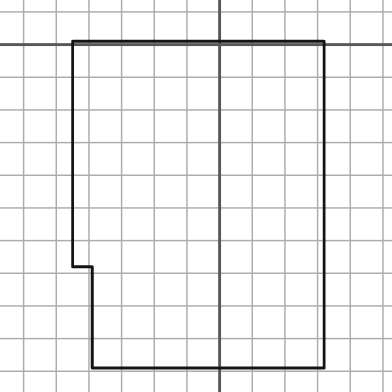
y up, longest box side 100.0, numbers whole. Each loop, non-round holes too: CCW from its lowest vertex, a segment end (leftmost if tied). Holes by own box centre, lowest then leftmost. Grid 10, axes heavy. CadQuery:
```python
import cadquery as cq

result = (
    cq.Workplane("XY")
    .moveTo(-39.0, -99.0)
    .lineTo(32.0, -99.0)
    .lineTo(32.0, 1.0)
    .lineTo(-45.0, 1.0)
    .lineTo(-45.0, -68.0)
    .lineTo(-39.0, -68.0)
    .close()
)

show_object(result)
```